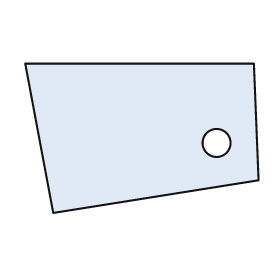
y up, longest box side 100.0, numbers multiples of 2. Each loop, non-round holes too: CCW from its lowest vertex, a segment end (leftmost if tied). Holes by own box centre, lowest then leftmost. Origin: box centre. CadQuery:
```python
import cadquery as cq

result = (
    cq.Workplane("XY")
    .moveTo(-38.0, -32.0)
    .lineTo(50.0, -18.0)
    .lineTo(48.0, 32.0)
    .lineTo(-50.0, 32.0)
    .close()
    .moveTo(32.0, -2.0)
    .circle(6.0)
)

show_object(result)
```